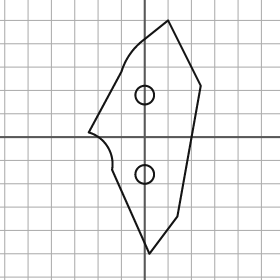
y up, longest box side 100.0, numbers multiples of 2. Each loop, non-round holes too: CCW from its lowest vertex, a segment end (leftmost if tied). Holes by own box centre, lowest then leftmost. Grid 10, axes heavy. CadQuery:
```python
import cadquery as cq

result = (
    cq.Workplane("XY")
    .moveTo(2.0, -50.0)
    .lineTo(14.0, -34.0)
    .lineTo(24.0, 22.0)
    .lineTo(10.0, 50.0)
    .lineTo(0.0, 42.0)
    .threePointArc((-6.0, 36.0), (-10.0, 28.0))
    .lineTo(-24.0, 2.0)
    .threePointArc((-16.0, -4.0), (-14.0, -14.0))
    .close()
    .moveTo(0.0, -16.0)
    .circle(4.0)
    .moveTo(0.0, 18.0)
    .circle(4.0)
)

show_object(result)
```